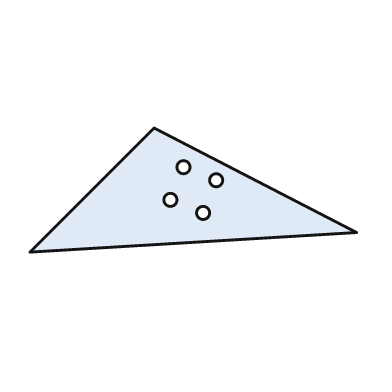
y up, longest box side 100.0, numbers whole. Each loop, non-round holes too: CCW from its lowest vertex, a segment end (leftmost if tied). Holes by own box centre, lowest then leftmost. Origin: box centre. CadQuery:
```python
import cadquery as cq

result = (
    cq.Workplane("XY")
    .moveTo(-50.0, -19.0)
    .lineTo(50.0, -13.0)
    .lineTo(-12.0, 19.0)
    .close()
    .moveTo(3.0, -7.0)
    .circle(2.0)
    .moveTo(-7.0, -3.0)
    .circle(2.0)
    .moveTo(7.0, 3.0)
    .circle(2.0)
    .moveTo(-3.0, 7.0)
    .circle(2.0)
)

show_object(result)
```